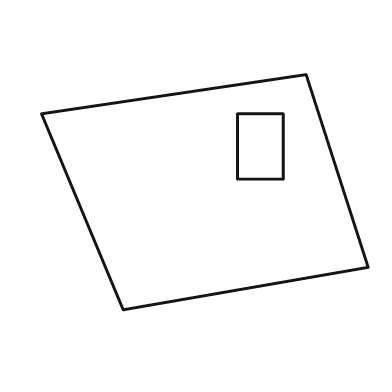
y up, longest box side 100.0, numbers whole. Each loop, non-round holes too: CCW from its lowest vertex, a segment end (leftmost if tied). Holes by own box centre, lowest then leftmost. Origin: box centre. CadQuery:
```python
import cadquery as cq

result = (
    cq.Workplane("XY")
    .moveTo(-25.0, -36.0)
    .lineTo(50.0, -23.0)
    .lineTo(31.0, 36.0)
    .lineTo(-50.0, 24.0)
    .close()
    .moveTo(10.0, 4.0)
    .lineTo(24.0, 4.0)
    .lineTo(24.0, 24.0)
    .lineTo(10.0, 24.0)
    .close()
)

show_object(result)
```